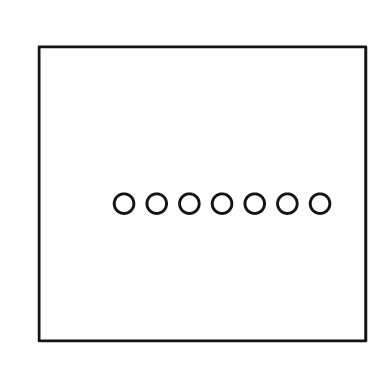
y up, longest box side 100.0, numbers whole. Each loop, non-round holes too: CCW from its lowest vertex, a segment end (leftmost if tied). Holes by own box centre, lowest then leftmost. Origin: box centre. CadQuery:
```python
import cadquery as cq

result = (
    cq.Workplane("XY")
    .moveTo(-50.0, -45.0)
    .lineTo(50.0, -45.0)
    .lineTo(50.0, 45.0)
    .lineTo(-50.0, 45.0)
    .close()
    .moveTo(-24.0, -3.0)
    .circle(3.0)
    .moveTo(-14.0, -3.0)
    .circle(3.0)
    .moveTo(-4.0, -3.0)
    .circle(3.0)
    .moveTo(6.0, -3.0)
    .circle(3.0)
    .moveTo(16.0, -3.0)
    .circle(3.0)
    .moveTo(26.0, -3.0)
    .circle(3.0)
    .moveTo(36.0, -3.0)
    .circle(3.0)
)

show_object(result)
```